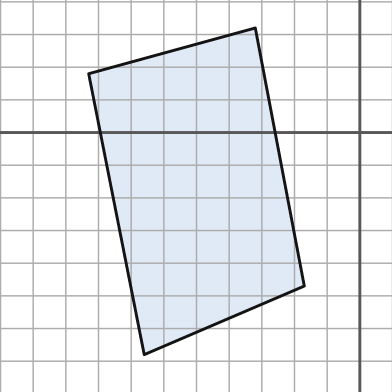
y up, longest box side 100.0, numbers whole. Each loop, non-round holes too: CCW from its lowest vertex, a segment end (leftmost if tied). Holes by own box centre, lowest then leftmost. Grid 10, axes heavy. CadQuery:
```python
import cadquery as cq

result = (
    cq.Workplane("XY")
    .moveTo(-66.0, -68.0)
    .lineTo(-17.0, -47.0)
    .lineTo(-32.0, 32.0)
    .lineTo(-83.0, 18.0)
    .close()
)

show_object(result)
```